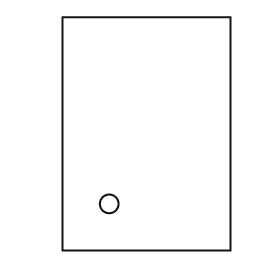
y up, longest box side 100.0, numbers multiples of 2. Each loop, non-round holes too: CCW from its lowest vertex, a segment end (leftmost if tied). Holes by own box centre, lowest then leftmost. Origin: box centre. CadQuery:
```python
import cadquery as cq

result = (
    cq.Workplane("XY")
    .moveTo(-36.0, -50.0)
    .lineTo(36.0, -50.0)
    .lineTo(36.0, 50.0)
    .lineTo(-36.0, 50.0)
    .close()
    .moveTo(-16.0, -30.0)
    .circle(4.0)
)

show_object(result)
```